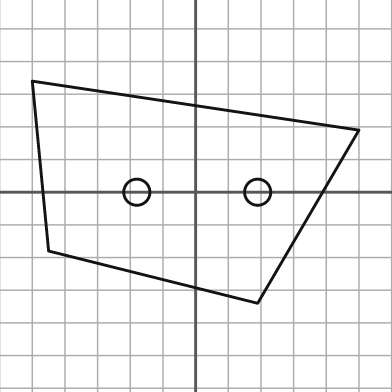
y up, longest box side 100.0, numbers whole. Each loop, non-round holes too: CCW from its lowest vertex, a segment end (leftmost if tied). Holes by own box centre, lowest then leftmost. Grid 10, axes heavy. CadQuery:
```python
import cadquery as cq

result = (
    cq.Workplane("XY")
    .moveTo(19.0, -34.0)
    .lineTo(50.0, 19.0)
    .lineTo(-50.0, 34.0)
    .lineTo(-45.0, -18.0)
    .close()
    .moveTo(-18.0, 0.0)
    .circle(4.0)
    .moveTo(19.0, 0.0)
    .circle(4.0)
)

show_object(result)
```